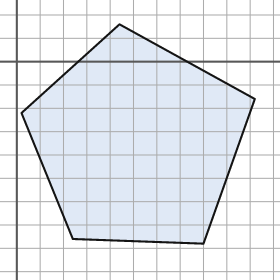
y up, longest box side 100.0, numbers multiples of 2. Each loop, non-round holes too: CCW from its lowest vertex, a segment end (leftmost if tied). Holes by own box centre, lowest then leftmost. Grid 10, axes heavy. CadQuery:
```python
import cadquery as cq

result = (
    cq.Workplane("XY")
    .moveTo(80.0, -78.0)
    .lineTo(102.0, -16.0)
    .lineTo(44.0, 16.0)
    .lineTo(2.0, -22.0)
    .lineTo(24.0, -76.0)
    .close()
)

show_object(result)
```